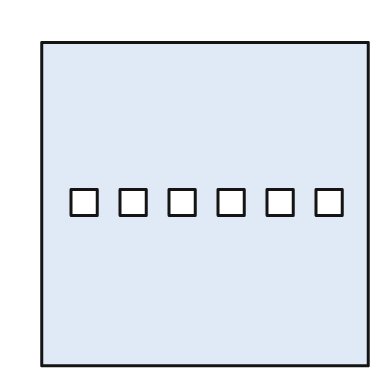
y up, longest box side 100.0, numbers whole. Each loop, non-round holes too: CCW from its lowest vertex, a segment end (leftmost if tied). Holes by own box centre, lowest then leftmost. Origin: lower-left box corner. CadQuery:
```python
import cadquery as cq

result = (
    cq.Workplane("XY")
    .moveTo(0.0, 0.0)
    .lineTo(100.0, 0.0)
    .lineTo(100.0, 99.0)
    .lineTo(0.0, 99.0)
    .close()
    .moveTo(9.0, 46.0)
    .lineTo(17.0, 46.0)
    .lineTo(17.0, 54.0)
    .lineTo(9.0, 54.0)
    .close()
    .moveTo(24.0, 46.0)
    .lineTo(32.0, 46.0)
    .lineTo(32.0, 54.0)
    .lineTo(24.0, 54.0)
    .close()
    .moveTo(39.0, 46.0)
    .lineTo(47.0, 46.0)
    .lineTo(47.0, 54.0)
    .lineTo(39.0, 54.0)
    .close()
    .moveTo(54.0, 46.0)
    .lineTo(62.0, 46.0)
    .lineTo(62.0, 54.0)
    .lineTo(54.0, 54.0)
    .close()
    .moveTo(69.0, 46.0)
    .lineTo(77.0, 46.0)
    .lineTo(77.0, 54.0)
    .lineTo(69.0, 54.0)
    .close()
    .moveTo(84.0, 46.0)
    .lineTo(92.0, 46.0)
    .lineTo(92.0, 54.0)
    .lineTo(84.0, 54.0)
    .close()
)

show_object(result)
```